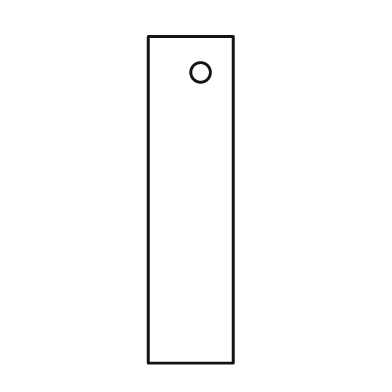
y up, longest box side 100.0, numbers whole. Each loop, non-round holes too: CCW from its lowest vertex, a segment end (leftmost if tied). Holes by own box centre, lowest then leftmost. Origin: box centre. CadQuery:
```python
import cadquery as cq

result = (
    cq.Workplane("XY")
    .moveTo(-13.0, -50.0)
    .lineTo(13.0, -50.0)
    .lineTo(13.0, 50.0)
    .lineTo(-13.0, 50.0)
    .close()
    .moveTo(3.0, 39.0)
    .circle(3.0)
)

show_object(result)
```